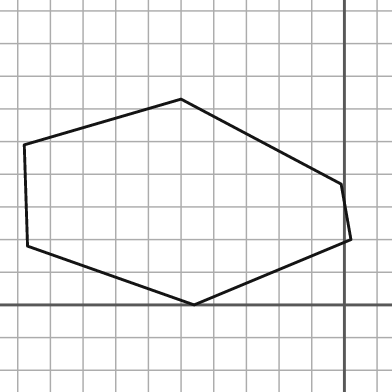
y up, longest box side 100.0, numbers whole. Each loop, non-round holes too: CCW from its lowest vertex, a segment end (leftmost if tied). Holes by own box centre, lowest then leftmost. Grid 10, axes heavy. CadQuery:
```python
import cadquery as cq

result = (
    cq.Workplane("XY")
    .moveTo(-46.0, 0.0)
    .lineTo(2.0, 20.0)
    .lineTo(-1.0, 37.0)
    .lineTo(-50.0, 63.0)
    .lineTo(-98.0, 49.0)
    .lineTo(-97.0, 18.0)
    .close()
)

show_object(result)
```